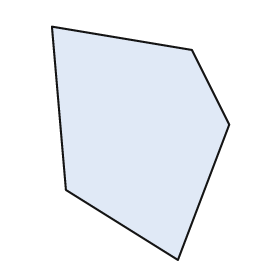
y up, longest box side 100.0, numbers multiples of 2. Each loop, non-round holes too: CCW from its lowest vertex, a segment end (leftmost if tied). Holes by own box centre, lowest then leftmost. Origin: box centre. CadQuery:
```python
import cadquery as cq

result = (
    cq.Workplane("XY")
    .moveTo(16.0, -50.0)
    .lineTo(38.0, 8.0)
    .lineTo(22.0, 40.0)
    .lineTo(-38.0, 50.0)
    .lineTo(-32.0, -20.0)
    .close()
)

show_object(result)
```